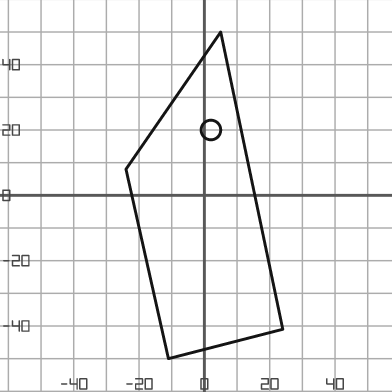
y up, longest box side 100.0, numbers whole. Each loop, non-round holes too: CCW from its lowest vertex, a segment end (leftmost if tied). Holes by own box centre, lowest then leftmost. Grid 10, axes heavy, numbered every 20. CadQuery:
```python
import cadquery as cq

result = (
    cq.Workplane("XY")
    .moveTo(-11.0, -50.0)
    .lineTo(24.0, -41.0)
    .lineTo(5.0, 50.0)
    .lineTo(-24.0, 8.0)
    .close()
    .moveTo(2.0, 20.0)
    .circle(3.0)
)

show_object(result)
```